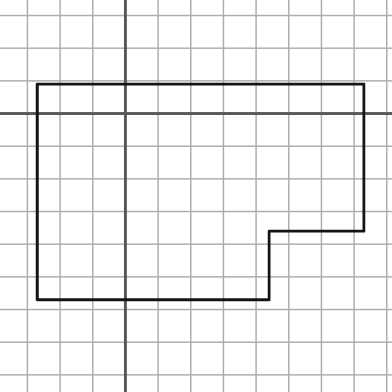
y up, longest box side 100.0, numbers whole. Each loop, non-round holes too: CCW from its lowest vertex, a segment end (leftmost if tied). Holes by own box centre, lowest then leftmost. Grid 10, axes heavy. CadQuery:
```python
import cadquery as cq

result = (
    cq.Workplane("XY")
    .moveTo(-27.0, -57.0)
    .lineTo(44.0, -57.0)
    .lineTo(44.0, -36.0)
    .lineTo(73.0, -36.0)
    .lineTo(73.0, 9.0)
    .lineTo(-27.0, 9.0)
    .close()
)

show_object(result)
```